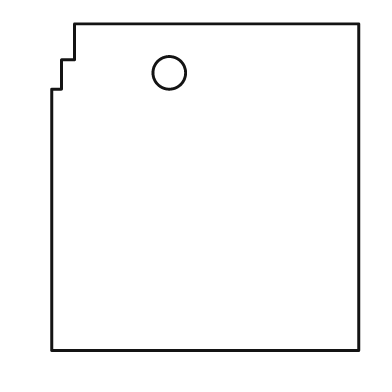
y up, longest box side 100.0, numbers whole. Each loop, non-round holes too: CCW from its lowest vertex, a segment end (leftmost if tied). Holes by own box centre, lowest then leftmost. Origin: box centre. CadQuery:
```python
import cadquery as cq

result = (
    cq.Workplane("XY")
    .moveTo(-47.0, -50.0)
    .lineTo(47.0, -50.0)
    .lineTo(47.0, 50.0)
    .lineTo(-40.0, 50.0)
    .lineTo(-40.0, 39.0)
    .lineTo(-44.0, 39.0)
    .lineTo(-44.0, 30.0)
    .lineTo(-47.0, 30.0)
    .close()
    .moveTo(-11.0, 35.0)
    .circle(5.0)
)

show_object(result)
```